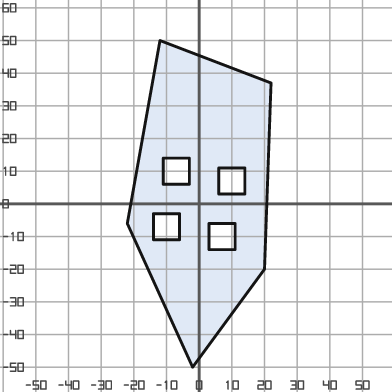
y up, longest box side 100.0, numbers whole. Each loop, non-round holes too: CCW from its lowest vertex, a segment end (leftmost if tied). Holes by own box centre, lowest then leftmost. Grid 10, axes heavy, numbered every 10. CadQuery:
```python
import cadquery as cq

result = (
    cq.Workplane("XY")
    .moveTo(-2.0, -50.0)
    .lineTo(20.0, -20.0)
    .lineTo(22.0, 37.0)
    .lineTo(-12.0, 50.0)
    .lineTo(-22.0, -6.0)
    .close()
    .moveTo(3.0, -14.0)
    .lineTo(11.0, -14.0)
    .lineTo(11.0, -6.0)
    .lineTo(3.0, -6.0)
    .close()
    .moveTo(-14.0, -11.0)
    .lineTo(-6.0, -11.0)
    .lineTo(-6.0, -3.0)
    .lineTo(-14.0, -3.0)
    .close()
    .moveTo(6.0, 3.0)
    .lineTo(14.0, 3.0)
    .lineTo(14.0, 11.0)
    .lineTo(6.0, 11.0)
    .close()
    .moveTo(-11.0, 6.0)
    .lineTo(-3.0, 6.0)
    .lineTo(-3.0, 14.0)
    .lineTo(-11.0, 14.0)
    .close()
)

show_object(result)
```